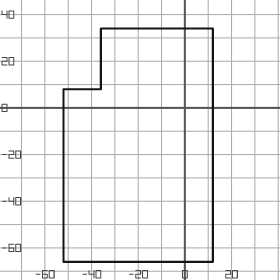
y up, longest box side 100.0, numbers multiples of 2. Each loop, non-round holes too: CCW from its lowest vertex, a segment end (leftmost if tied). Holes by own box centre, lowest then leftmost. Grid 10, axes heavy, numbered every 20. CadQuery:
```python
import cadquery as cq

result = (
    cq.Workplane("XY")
    .moveTo(-52.0, -66.0)
    .lineTo(12.0, -66.0)
    .lineTo(12.0, 34.0)
    .lineTo(-36.0, 34.0)
    .lineTo(-36.0, 8.0)
    .lineTo(-52.0, 8.0)
    .close()
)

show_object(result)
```